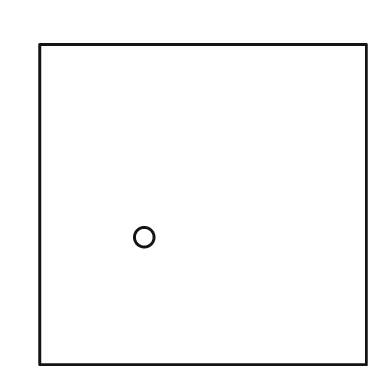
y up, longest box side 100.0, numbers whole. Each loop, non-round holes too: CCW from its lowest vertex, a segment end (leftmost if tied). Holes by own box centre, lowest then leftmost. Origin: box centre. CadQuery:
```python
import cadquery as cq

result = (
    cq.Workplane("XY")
    .moveTo(-50.0, -49.0)
    .lineTo(50.0, -49.0)
    .lineTo(50.0, 49.0)
    .lineTo(-50.0, 49.0)
    .close()
    .moveTo(-18.0, -10.0)
    .circle(3.0)
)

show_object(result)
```